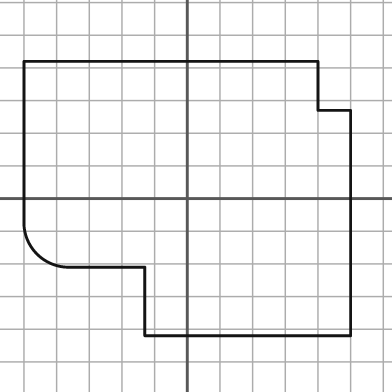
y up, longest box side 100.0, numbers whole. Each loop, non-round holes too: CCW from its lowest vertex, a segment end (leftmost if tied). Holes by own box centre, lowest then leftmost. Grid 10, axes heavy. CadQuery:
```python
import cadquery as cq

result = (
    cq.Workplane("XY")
    .moveTo(-13.0, -42.0)
    .lineTo(50.0, -42.0)
    .lineTo(50.0, 27.0)
    .lineTo(40.0, 27.0)
    .lineTo(40.0, 42.0)
    .lineTo(-50.0, 42.0)
    .lineTo(-50.0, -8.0)
    .threePointArc((-46.0, -17.0), (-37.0, -21.0))
    .lineTo(-13.0, -21.0)
    .close()
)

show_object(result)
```